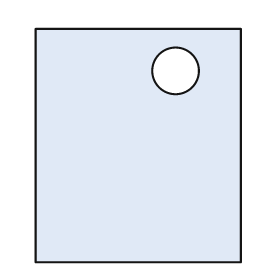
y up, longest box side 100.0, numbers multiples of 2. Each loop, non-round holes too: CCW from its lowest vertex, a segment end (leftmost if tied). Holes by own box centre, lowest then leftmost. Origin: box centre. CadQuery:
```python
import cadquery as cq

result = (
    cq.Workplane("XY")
    .moveTo(-44.0, -50.0)
    .lineTo(44.0, -50.0)
    .lineTo(44.0, 50.0)
    .lineTo(-44.0, 50.0)
    .close()
    .moveTo(16.0, 32.0)
    .circle(10.0)
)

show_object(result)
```